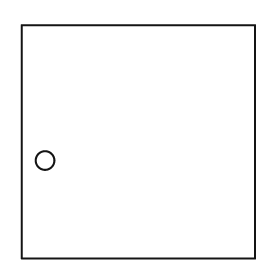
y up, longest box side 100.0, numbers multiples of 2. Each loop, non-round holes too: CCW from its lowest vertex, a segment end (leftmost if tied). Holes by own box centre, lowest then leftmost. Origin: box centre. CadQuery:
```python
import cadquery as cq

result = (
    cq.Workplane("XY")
    .moveTo(-50.0, -50.0)
    .lineTo(50.0, -50.0)
    .lineTo(50.0, 50.0)
    .lineTo(-50.0, 50.0)
    .close()
    .moveTo(-40.0, -8.0)
    .circle(4.0)
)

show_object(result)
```